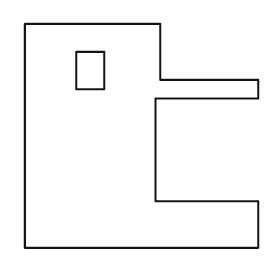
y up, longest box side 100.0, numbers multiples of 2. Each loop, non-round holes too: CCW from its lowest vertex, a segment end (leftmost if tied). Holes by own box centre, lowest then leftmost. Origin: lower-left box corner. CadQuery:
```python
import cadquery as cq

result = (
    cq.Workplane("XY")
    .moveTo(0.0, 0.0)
    .lineTo(100.0, 0.0)
    .lineTo(100.0, 20.0)
    .lineTo(56.0, 20.0)
    .lineTo(56.0, 64.0)
    .lineTo(100.0, 64.0)
    .lineTo(100.0, 72.0)
    .lineTo(58.0, 72.0)
    .lineTo(58.0, 96.0)
    .lineTo(0.0, 96.0)
    .close()
    .moveTo(22.0, 68.0)
    .lineTo(34.0, 68.0)
    .lineTo(34.0, 84.0)
    .lineTo(22.0, 84.0)
    .close()
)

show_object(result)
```